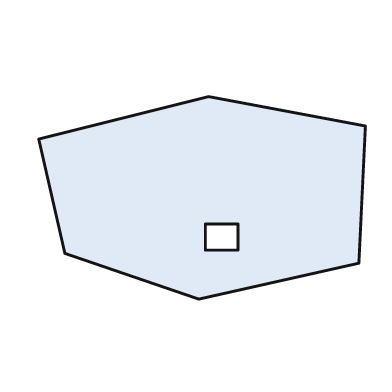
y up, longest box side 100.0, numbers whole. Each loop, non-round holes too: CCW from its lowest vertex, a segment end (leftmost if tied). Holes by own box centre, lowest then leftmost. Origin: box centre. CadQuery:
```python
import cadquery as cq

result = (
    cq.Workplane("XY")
    .moveTo(-1.0, -31.0)
    .lineTo(48.0, -20.0)
    .lineTo(50.0, 22.0)
    .lineTo(2.0, 31.0)
    .lineTo(-50.0, 18.0)
    .lineTo(-42.0, -17.0)
    .close()
    .moveTo(1.0, -16.0)
    .lineTo(11.0, -16.0)
    .lineTo(11.0, -8.0)
    .lineTo(1.0, -8.0)
    .close()
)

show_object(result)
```